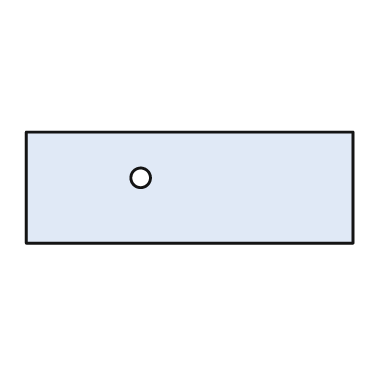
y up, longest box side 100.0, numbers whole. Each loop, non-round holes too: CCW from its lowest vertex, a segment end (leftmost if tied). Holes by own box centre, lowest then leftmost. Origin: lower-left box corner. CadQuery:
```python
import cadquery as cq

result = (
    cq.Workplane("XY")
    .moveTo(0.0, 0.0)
    .lineTo(100.0, 0.0)
    .lineTo(100.0, 34.0)
    .lineTo(0.0, 34.0)
    .close()
    .moveTo(35.0, 20.0)
    .circle(3.0)
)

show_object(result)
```